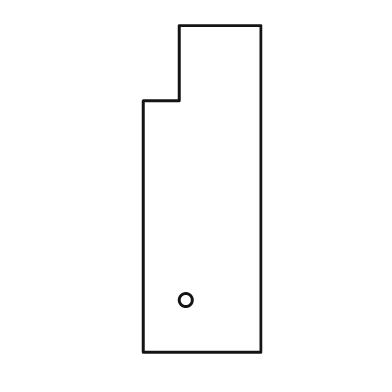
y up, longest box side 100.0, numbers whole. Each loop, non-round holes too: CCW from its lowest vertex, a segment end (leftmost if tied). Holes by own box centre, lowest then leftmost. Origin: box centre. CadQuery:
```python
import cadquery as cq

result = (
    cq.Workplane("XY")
    .moveTo(-18.0, -50.0)
    .lineTo(18.0, -50.0)
    .lineTo(18.0, 50.0)
    .lineTo(-7.0, 50.0)
    .lineTo(-7.0, 27.0)
    .lineTo(-18.0, 27.0)
    .close()
    .moveTo(-5.0, -34.0)
    .circle(2.0)
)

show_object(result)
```